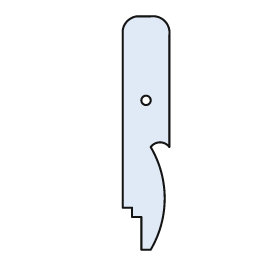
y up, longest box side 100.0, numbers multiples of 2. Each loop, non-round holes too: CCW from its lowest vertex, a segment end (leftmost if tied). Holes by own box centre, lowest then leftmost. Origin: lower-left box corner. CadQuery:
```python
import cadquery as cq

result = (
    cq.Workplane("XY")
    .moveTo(8.0, 0.0)
    .lineTo(12.0, 0.0)
    .threePointArc((18.0, 22.0), (12.0, 44.0))
    .threePointArc((16.0, 46.0), (20.0, 44.0))
    .lineTo(20.0, 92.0)
    .threePointArc((18.0, 98.0), (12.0, 100.0))
    .lineTo(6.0, 100.0)
    .threePointArc((2.0, 98.0), (0.0, 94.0))
    .lineTo(0.0, 18.0)
    .lineTo(4.0, 18.0)
    .lineTo(4.0, 14.0)
    .lineTo(8.0, 14.0)
    .close()
    .moveTo(10.0, 64.0)
    .circle(2.0)
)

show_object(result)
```